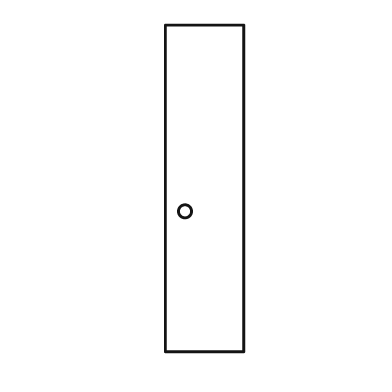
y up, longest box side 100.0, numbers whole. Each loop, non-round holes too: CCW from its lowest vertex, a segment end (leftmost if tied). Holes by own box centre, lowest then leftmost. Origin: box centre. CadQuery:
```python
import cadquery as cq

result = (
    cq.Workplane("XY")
    .moveTo(-12.0, -50.0)
    .lineTo(12.0, -50.0)
    .lineTo(12.0, 50.0)
    .lineTo(-12.0, 50.0)
    .close()
    .moveTo(-6.0, -7.0)
    .circle(2.0)
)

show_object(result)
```